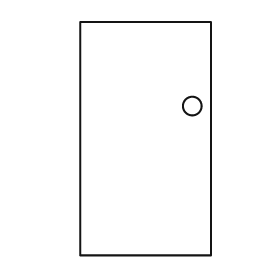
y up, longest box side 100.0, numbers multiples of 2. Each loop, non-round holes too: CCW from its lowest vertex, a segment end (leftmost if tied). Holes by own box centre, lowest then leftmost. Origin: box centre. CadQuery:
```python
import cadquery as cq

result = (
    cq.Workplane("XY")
    .moveTo(-28.0, -50.0)
    .lineTo(28.0, -50.0)
    .lineTo(28.0, 50.0)
    .lineTo(-28.0, 50.0)
    .close()
    .moveTo(20.0, 14.0)
    .circle(4.0)
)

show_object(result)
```